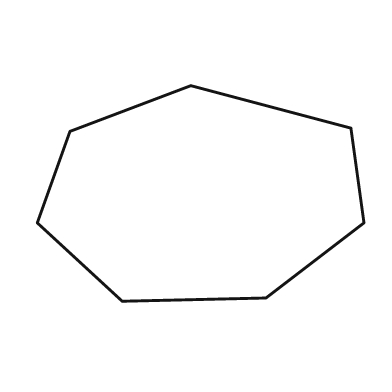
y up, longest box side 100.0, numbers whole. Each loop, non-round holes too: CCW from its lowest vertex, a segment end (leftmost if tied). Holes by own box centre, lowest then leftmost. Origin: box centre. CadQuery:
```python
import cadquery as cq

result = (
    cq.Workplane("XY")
    .moveTo(-24.0, -33.0)
    .lineTo(20.0, -32.0)
    .lineTo(50.0, -9.0)
    .lineTo(46.0, 20.0)
    .lineTo(-3.0, 33.0)
    .lineTo(-40.0, 19.0)
    .lineTo(-50.0, -9.0)
    .close()
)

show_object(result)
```